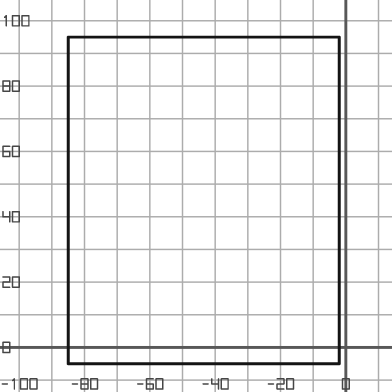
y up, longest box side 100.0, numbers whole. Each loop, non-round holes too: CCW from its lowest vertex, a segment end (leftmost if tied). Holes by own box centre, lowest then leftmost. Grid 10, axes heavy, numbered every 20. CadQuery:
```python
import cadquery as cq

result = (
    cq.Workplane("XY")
    .moveTo(-85.0, -5.0)
    .lineTo(-2.0, -5.0)
    .lineTo(-2.0, 95.0)
    .lineTo(-85.0, 95.0)
    .close()
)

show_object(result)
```